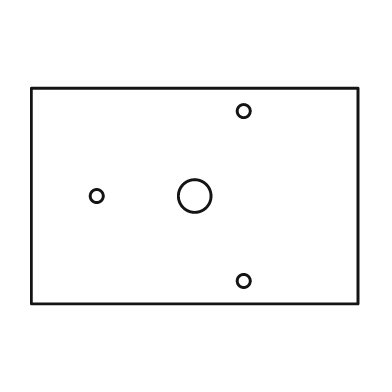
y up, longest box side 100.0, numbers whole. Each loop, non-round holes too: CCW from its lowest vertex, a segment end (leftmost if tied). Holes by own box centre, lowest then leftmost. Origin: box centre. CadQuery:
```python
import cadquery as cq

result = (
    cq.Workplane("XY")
    .moveTo(-50.0, -33.0)
    .lineTo(50.0, -33.0)
    .lineTo(50.0, 33.0)
    .lineTo(-50.0, 33.0)
    .close()
    .moveTo(15.0, -26.0)
    .circle(2.0)
    .moveTo(-30.0, 0.0)
    .circle(2.0)
    .moveTo(0.0, 0.0)
    .circle(5.0)
    .moveTo(15.0, 26.0)
    .circle(2.0)
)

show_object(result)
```